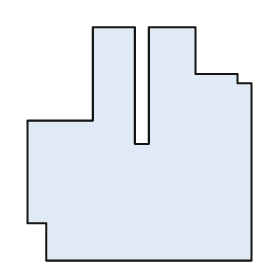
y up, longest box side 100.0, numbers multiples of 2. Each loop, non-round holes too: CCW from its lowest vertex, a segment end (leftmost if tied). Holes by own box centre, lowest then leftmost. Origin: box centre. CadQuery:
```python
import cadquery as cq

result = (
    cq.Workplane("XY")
    .moveTo(-40.0, -50.0)
    .lineTo(48.0, -50.0)
    .lineTo(48.0, 26.0)
    .lineTo(42.0, 26.0)
    .lineTo(42.0, 30.0)
    .lineTo(24.0, 30.0)
    .lineTo(24.0, 50.0)
    .lineTo(4.0, 50.0)
    .lineTo(4.0, 0.0)
    .lineTo(-2.0, 0.0)
    .lineTo(-2.0, 50.0)
    .lineTo(-20.0, 50.0)
    .lineTo(-20.0, 10.0)
    .lineTo(-48.0, 10.0)
    .lineTo(-48.0, -34.0)
    .lineTo(-40.0, -34.0)
    .close()
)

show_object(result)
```